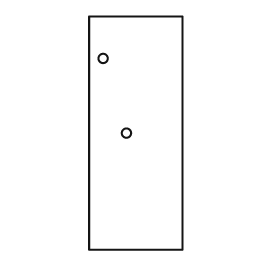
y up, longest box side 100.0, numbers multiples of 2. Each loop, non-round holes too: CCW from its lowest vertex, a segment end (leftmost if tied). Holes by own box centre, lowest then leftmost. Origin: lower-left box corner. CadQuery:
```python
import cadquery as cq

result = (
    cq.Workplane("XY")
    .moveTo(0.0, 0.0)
    .lineTo(40.0, 0.0)
    .lineTo(40.0, 100.0)
    .lineTo(0.0, 100.0)
    .close()
    .moveTo(16.0, 50.0)
    .circle(2.0)
    .moveTo(6.0, 82.0)
    .circle(2.0)
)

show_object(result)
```